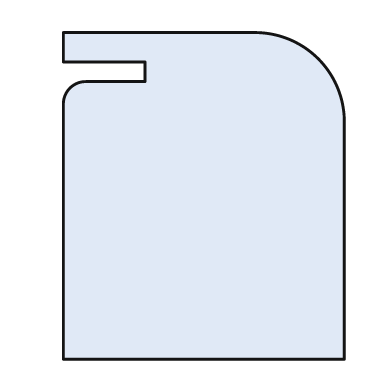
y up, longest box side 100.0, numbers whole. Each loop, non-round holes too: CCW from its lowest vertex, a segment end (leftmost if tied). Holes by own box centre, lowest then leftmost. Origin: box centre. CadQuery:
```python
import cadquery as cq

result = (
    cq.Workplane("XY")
    .moveTo(-43.0, -50.0)
    .lineTo(43.0, -50.0)
    .lineTo(43.0, 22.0)
    .threePointArc((35.0, 42.0), (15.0, 50.0))
    .lineTo(-43.0, 50.0)
    .lineTo(-43.0, 41.0)
    .lineTo(-18.0, 41.0)
    .lineTo(-18.0, 35.0)
    .lineTo(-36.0, 35.0)
    .threePointArc((-41.0, 33.0), (-43.0, 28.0))
    .close()
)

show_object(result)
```